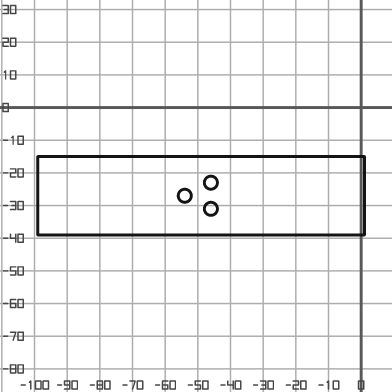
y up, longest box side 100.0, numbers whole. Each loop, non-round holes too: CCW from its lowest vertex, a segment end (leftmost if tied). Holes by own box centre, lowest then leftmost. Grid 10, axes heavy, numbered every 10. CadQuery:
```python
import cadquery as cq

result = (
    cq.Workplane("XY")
    .moveTo(-99.0, -39.0)
    .lineTo(1.0, -39.0)
    .lineTo(1.0, -15.0)
    .lineTo(-99.0, -15.0)
    .close()
    .moveTo(-46.0, -31.0)
    .circle(2.0)
    .moveTo(-54.0, -27.0)
    .circle(2.0)
    .moveTo(-46.0, -23.0)
    .circle(2.0)
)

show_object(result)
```